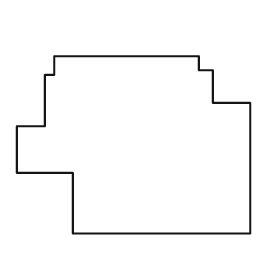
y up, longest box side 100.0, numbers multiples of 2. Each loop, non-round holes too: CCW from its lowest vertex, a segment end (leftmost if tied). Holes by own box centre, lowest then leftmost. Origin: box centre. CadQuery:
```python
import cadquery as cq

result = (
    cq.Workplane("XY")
    .moveTo(-26.0, -38.0)
    .lineTo(50.0, -38.0)
    .lineTo(50.0, 18.0)
    .lineTo(34.0, 18.0)
    .lineTo(34.0, 32.0)
    .lineTo(28.0, 32.0)
    .lineTo(28.0, 38.0)
    .lineTo(-34.0, 38.0)
    .lineTo(-34.0, 30.0)
    .lineTo(-38.0, 30.0)
    .lineTo(-38.0, 8.0)
    .lineTo(-50.0, 8.0)
    .lineTo(-50.0, -12.0)
    .lineTo(-26.0, -12.0)
    .close()
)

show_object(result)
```